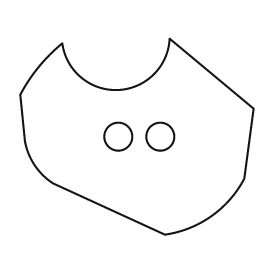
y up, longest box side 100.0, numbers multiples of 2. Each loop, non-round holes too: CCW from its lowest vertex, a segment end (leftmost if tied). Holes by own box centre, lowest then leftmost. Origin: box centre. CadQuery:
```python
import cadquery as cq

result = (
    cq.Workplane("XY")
    .moveTo(12.0, -42.0)
    .threePointArc((32.0, -34.0), (46.0, -18.0))
    .lineTo(50.0, 12.0)
    .lineTo(14.0, 42.0)
    .threePointArc((-8.0, 20.0), (-32.0, 40.0))
    .threePointArc((-42.0, 30.0), (-50.0, 18.0))
    .lineTo(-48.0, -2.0)
    .threePointArc((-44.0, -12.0), (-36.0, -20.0))
    .close()
    .moveTo(-8.0, 0.0)
    .circle(6.0)
    .moveTo(10.0, 0.0)
    .circle(6.0)
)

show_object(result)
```